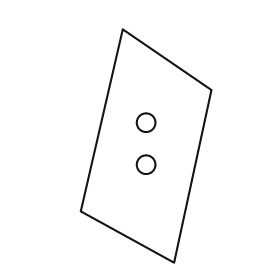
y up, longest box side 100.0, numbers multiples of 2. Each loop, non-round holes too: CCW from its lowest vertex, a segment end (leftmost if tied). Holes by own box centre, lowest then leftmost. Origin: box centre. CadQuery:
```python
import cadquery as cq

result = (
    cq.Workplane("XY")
    .moveTo(12.0, -50.0)
    .lineTo(28.0, 24.0)
    .lineTo(-10.0, 50.0)
    .lineTo(-28.0, -28.0)
    .close()
    .moveTo(0.0, -8.0)
    .circle(4.0)
    .moveTo(0.0, 10.0)
    .circle(4.0)
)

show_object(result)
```